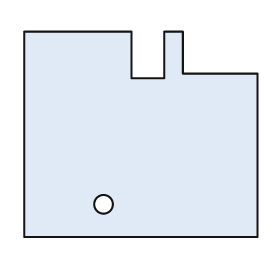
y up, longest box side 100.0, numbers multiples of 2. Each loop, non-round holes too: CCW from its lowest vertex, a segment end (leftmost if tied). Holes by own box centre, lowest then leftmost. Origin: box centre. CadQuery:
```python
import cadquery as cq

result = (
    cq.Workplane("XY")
    .moveTo(-50.0, -44.0)
    .lineTo(50.0, -44.0)
    .lineTo(50.0, 26.0)
    .lineTo(18.0, 26.0)
    .lineTo(18.0, 44.0)
    .lineTo(10.0, 44.0)
    .lineTo(10.0, 24.0)
    .lineTo(-4.0, 24.0)
    .lineTo(-4.0, 44.0)
    .lineTo(-50.0, 44.0)
    .close()
    .moveTo(-16.0, -30.0)
    .circle(4.0)
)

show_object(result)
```